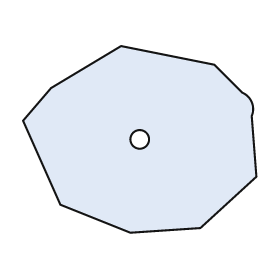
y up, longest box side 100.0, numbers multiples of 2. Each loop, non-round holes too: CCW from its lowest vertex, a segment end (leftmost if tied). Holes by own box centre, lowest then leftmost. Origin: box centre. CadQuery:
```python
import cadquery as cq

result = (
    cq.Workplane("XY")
    .moveTo(-4.0, -40.0)
    .lineTo(26.0, -38.0)
    .lineTo(50.0, -16.0)
    .lineTo(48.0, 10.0)
    .threePointArc((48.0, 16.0), (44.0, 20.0))
    .lineTo(32.0, 32.0)
    .lineTo(-8.0, 40.0)
    .lineTo(-38.0, 22.0)
    .lineTo(-50.0, 8.0)
    .lineTo(-34.0, -28.0)
    .close()
    .moveTo(0.0, 0.0)
    .circle(4.0)
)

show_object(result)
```